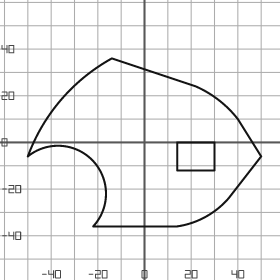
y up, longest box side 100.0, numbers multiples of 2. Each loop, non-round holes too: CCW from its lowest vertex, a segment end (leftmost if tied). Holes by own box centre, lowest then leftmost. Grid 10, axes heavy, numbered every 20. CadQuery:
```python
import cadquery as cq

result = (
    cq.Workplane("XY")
    .moveTo(-22.0, -36.0)
    .lineTo(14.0, -36.0)
    .threePointArc((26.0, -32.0), (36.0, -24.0))
    .lineTo(50.0, -6.0)
    .lineTo(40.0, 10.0)
    .threePointArc((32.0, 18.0), (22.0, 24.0))
    .lineTo(-14.0, 36.0)
    .threePointArc((-36.0, 18.0), (-50.0, -6.0))
    .threePointArc((-22.0, -8.0), (-22.0, -36.0))
    .close()
    .moveTo(14.0, -12.0)
    .lineTo(30.0, -12.0)
    .lineTo(30.0, 0.0)
    .lineTo(14.0, 0.0)
    .close()
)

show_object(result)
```